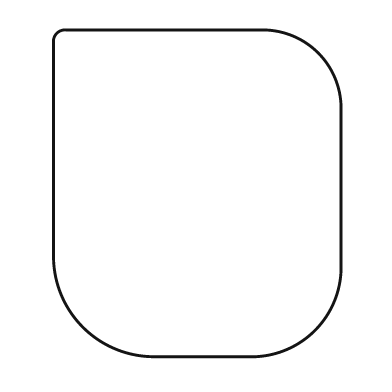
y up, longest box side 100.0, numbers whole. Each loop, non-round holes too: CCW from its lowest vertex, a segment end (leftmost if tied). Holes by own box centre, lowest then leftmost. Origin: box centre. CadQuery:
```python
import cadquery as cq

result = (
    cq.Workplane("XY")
    .moveTo(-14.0, -50.0)
    .lineTo(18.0, -50.0)
    .threePointArc((36.0, -42.0), (44.0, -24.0))
    .lineTo(44.0, 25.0)
    .threePointArc((37.0, 43.0), (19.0, 50.0))
    .lineTo(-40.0, 50.0)
    .threePointArc((-43.0, 49.0), (-44.0, 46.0))
    .lineTo(-44.0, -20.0)
    .threePointArc((-35.0, -41.0), (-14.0, -50.0))
    .close()
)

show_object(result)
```